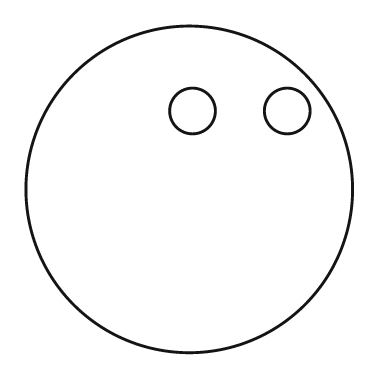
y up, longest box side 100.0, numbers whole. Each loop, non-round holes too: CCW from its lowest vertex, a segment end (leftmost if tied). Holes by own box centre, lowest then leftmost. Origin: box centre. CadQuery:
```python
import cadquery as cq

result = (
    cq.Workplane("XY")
    .moveTo(0.0, 0.0)
    .circle(50.0)
    .moveTo(1.0, 24.0)
    .circle(7.0)
    .moveTo(30.0, 24.0)
    .circle(7.0)
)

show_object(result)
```